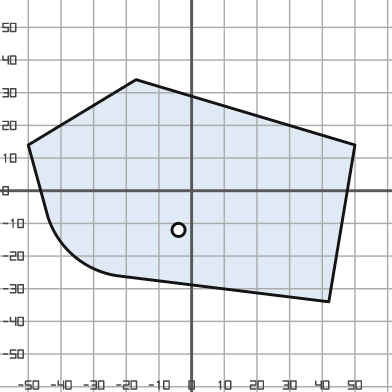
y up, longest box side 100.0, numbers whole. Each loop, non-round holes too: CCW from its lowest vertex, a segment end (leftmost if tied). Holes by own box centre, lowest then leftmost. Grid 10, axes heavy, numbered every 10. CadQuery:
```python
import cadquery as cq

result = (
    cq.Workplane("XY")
    .moveTo(42.0, -34.0)
    .lineTo(50.0, 14.0)
    .lineTo(-17.0, 34.0)
    .lineTo(-50.0, 14.0)
    .lineTo(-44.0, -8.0)
    .threePointArc((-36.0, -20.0), (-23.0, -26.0))
    .close()
    .moveTo(-4.0, -12.0)
    .circle(2.0)
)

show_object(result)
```